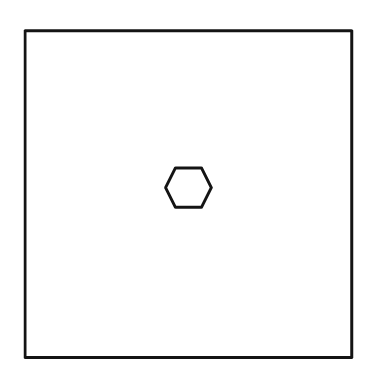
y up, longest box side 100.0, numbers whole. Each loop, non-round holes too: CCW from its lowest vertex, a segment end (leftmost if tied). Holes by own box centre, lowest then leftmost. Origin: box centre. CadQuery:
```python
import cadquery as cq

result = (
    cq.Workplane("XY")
    .moveTo(-50.0, -50.0)
    .lineTo(50.0, -50.0)
    .lineTo(50.0, 50.0)
    .lineTo(-50.0, 50.0)
    .close()
    .moveTo(-4.0, -4.0)
    .lineTo(4.0, -4.0)
    .lineTo(7.0, 2.0)
    .lineTo(4.0, 8.0)
    .lineTo(-4.0, 8.0)
    .lineTo(-7.0, 2.0)
    .close()
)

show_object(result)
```